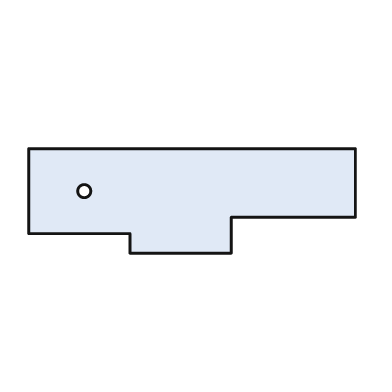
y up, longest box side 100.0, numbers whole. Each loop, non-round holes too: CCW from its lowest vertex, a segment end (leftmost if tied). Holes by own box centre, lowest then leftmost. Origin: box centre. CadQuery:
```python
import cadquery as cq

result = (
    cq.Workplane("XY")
    .moveTo(-19.0, -16.0)
    .lineTo(12.0, -16.0)
    .lineTo(12.0, -5.0)
    .lineTo(50.0, -5.0)
    .lineTo(50.0, 16.0)
    .lineTo(-50.0, 16.0)
    .lineTo(-50.0, -10.0)
    .lineTo(-19.0, -10.0)
    .close()
    .moveTo(-33.0, 3.0)
    .circle(2.0)
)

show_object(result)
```